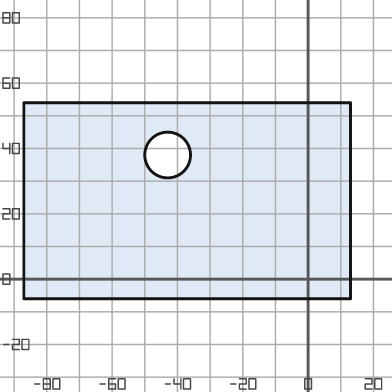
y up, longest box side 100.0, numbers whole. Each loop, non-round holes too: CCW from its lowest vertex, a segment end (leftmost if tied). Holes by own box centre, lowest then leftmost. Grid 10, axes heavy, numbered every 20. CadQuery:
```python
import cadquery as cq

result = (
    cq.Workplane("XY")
    .moveTo(-87.0, -6.0)
    .lineTo(13.0, -6.0)
    .lineTo(13.0, 54.0)
    .lineTo(-87.0, 54.0)
    .close()
    .moveTo(-43.0, 38.0)
    .circle(7.0)
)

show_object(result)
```